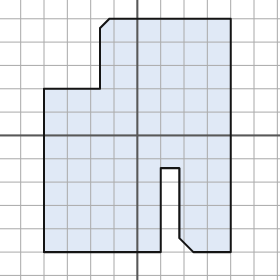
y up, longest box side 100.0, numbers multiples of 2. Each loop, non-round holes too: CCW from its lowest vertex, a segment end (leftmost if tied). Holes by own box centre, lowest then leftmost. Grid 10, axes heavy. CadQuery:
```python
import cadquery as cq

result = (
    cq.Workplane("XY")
    .moveTo(-40.0, -50.0)
    .lineTo(10.0, -50.0)
    .lineTo(10.0, -14.0)
    .lineTo(18.0, -14.0)
    .lineTo(18.0, -44.0)
    .lineTo(24.0, -50.0)
    .lineTo(40.0, -50.0)
    .lineTo(40.0, 50.0)
    .lineTo(-12.0, 50.0)
    .lineTo(-16.0, 46.0)
    .lineTo(-16.0, 20.0)
    .lineTo(-40.0, 20.0)
    .close()
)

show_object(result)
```